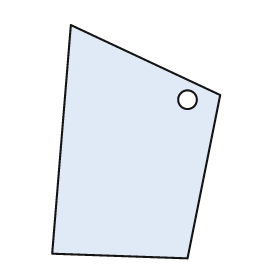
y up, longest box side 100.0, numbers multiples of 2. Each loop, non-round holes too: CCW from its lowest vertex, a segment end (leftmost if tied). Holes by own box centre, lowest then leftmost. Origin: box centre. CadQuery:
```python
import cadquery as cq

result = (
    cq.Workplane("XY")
    .moveTo(22.0, -50.0)
    .lineTo(36.0, 20.0)
    .lineTo(-28.0, 50.0)
    .lineTo(-36.0, -48.0)
    .close()
    .moveTo(22.0, 18.0)
    .circle(4.0)
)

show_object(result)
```